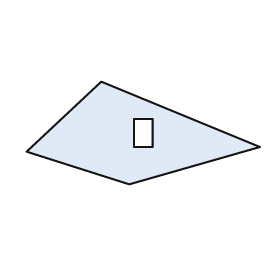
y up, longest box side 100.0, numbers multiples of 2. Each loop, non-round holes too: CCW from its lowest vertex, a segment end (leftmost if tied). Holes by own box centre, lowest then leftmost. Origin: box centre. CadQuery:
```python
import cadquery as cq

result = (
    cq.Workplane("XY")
    .moveTo(-6.0, -22.0)
    .lineTo(50.0, -6.0)
    .lineTo(-18.0, 22.0)
    .lineTo(-50.0, -8.0)
    .close()
    .moveTo(-4.0, -6.0)
    .lineTo(4.0, -6.0)
    .lineTo(4.0, 6.0)
    .lineTo(-4.0, 6.0)
    .close()
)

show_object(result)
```